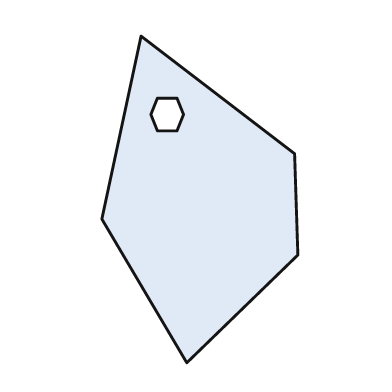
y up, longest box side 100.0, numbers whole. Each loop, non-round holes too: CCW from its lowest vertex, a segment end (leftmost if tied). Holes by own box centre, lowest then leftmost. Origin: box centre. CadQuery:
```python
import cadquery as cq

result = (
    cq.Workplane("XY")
    .moveTo(-4.0, -50.0)
    .lineTo(30.0, -17.0)
    .lineTo(29.0, 14.0)
    .lineTo(-18.0, 50.0)
    .lineTo(-30.0, -6.0)
    .close()
    .moveTo(-13.0, 21.0)
    .lineTo(-7.0, 21.0)
    .lineTo(-5.0, 26.0)
    .lineTo(-7.0, 31.0)
    .lineTo(-13.0, 31.0)
    .lineTo(-15.0, 26.0)
    .close()
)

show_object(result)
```